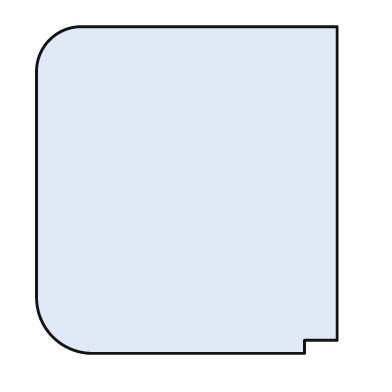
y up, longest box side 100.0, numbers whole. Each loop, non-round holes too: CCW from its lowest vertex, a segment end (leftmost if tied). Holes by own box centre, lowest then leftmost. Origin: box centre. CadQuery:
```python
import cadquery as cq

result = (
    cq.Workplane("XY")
    .moveTo(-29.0, -50.0)
    .lineTo(36.0, -50.0)
    .lineTo(36.0, -46.0)
    .lineTo(46.0, -46.0)
    .lineTo(46.0, 50.0)
    .lineTo(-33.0, 50.0)
    .threePointArc((-42.0, 46.0), (-46.0, 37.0))
    .lineTo(-46.0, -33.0)
    .threePointArc((-41.0, -45.0), (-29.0, -50.0))
    .close()
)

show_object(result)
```